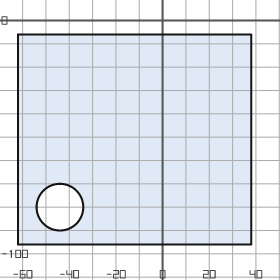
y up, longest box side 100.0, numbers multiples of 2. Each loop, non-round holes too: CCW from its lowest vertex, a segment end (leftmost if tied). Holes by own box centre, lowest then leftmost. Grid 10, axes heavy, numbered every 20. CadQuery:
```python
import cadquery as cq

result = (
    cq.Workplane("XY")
    .moveTo(-62.0, -96.0)
    .lineTo(38.0, -96.0)
    .lineTo(38.0, -6.0)
    .lineTo(-62.0, -6.0)
    .close()
    .moveTo(-44.0, -80.0)
    .circle(10.0)
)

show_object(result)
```